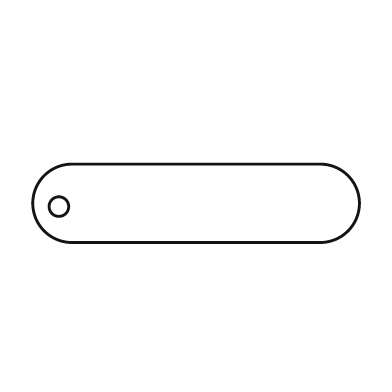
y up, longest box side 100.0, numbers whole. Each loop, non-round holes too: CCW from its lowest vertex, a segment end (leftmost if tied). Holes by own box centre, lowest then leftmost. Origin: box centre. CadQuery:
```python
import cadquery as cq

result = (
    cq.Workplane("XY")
    .moveTo(-38.0, -12.0)
    .lineTo(38.0, -12.0)
    .threePointArc((50.0, 0.0), (38.0, 12.0))
    .lineTo(-38.0, 12.0)
    .threePointArc((-50.0, 0.0), (-38.0, -12.0))
    .close()
    .moveTo(-42.0, -1.0)
    .circle(3.0)
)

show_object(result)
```